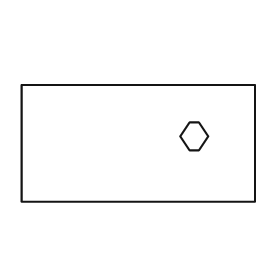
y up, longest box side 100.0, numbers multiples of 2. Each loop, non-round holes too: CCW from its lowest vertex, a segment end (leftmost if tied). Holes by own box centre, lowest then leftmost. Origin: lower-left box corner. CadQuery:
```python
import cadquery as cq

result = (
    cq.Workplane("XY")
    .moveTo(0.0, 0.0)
    .lineTo(100.0, 0.0)
    .lineTo(100.0, 50.0)
    .lineTo(0.0, 50.0)
    .close()
    .moveTo(72.0, 22.0)
    .lineTo(76.0, 22.0)
    .lineTo(80.0, 28.0)
    .lineTo(76.0, 34.0)
    .lineTo(72.0, 34.0)
    .lineTo(68.0, 28.0)
    .close()
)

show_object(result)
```